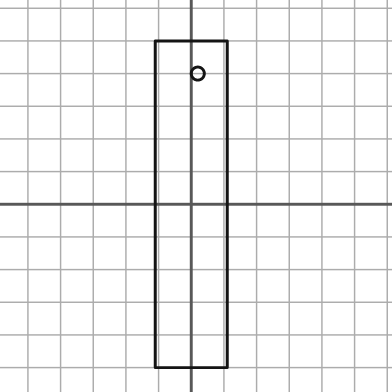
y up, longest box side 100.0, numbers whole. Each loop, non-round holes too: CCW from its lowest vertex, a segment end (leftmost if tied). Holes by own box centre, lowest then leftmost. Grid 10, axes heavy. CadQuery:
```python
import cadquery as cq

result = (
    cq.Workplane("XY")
    .moveTo(-11.0, -50.0)
    .lineTo(11.0, -50.0)
    .lineTo(11.0, 50.0)
    .lineTo(-11.0, 50.0)
    .close()
    .moveTo(2.0, 40.0)
    .circle(2.0)
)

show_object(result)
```